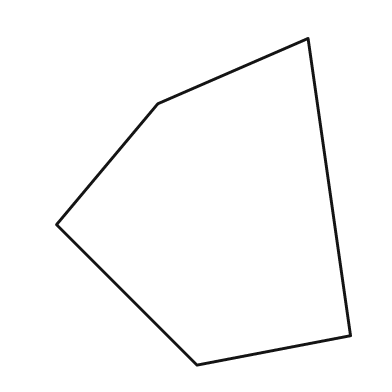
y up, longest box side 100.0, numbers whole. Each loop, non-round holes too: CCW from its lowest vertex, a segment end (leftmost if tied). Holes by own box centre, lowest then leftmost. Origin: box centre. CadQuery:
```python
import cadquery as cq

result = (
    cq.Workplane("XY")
    .moveTo(-2.0, -50.0)
    .lineTo(45.0, -41.0)
    .lineTo(32.0, 50.0)
    .lineTo(-14.0, 30.0)
    .lineTo(-45.0, -7.0)
    .close()
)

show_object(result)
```